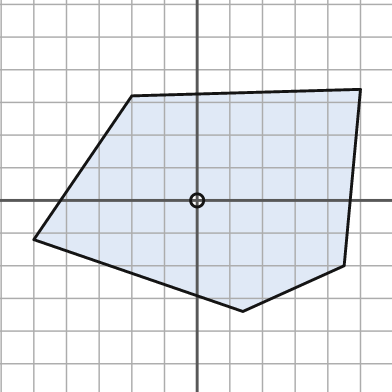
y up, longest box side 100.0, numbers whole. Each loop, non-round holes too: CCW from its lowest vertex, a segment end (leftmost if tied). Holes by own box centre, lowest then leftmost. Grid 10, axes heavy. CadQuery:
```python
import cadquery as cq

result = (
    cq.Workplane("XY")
    .moveTo(14.0, -34.0)
    .lineTo(45.0, -20.0)
    .lineTo(50.0, 34.0)
    .lineTo(-20.0, 32.0)
    .lineTo(-50.0, -12.0)
    .close()
    .moveTo(0.0, 0.0)
    .circle(2.0)
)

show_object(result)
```